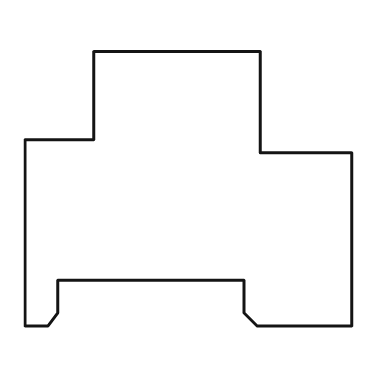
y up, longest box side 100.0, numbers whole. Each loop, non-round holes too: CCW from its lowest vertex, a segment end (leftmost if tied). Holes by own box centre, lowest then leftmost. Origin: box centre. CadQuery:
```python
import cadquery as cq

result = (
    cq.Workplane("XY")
    .moveTo(-50.0, -42.0)
    .lineTo(-43.0, -42.0)
    .lineTo(-40.0, -38.0)
    .lineTo(-40.0, -28.0)
    .lineTo(17.0, -28.0)
    .lineTo(17.0, -38.0)
    .lineTo(21.0, -42.0)
    .lineTo(50.0, -42.0)
    .lineTo(50.0, 11.0)
    .lineTo(22.0, 11.0)
    .lineTo(22.0, 42.0)
    .lineTo(-29.0, 42.0)
    .lineTo(-29.0, 15.0)
    .lineTo(-50.0, 15.0)
    .close()
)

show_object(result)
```